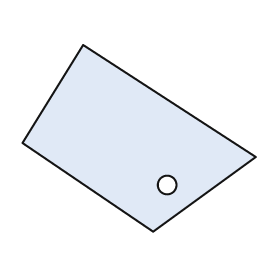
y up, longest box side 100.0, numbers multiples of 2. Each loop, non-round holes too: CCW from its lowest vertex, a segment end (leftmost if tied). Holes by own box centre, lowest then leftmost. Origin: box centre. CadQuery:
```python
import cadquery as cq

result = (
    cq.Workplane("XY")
    .moveTo(6.0, -40.0)
    .lineTo(50.0, -8.0)
    .lineTo(-24.0, 40.0)
    .lineTo(-50.0, -2.0)
    .close()
    .moveTo(12.0, -20.0)
    .circle(4.0)
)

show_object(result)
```